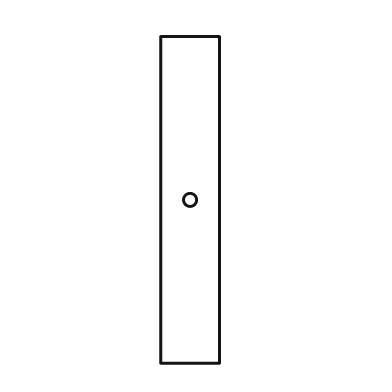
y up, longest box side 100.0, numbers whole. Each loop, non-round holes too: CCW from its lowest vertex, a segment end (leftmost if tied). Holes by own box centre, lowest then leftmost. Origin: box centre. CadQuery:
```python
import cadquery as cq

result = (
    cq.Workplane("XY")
    .moveTo(-9.0, -50.0)
    .lineTo(9.0, -50.0)
    .lineTo(9.0, 50.0)
    .lineTo(-9.0, 50.0)
    .close()
    .moveTo(0.0, 0.0)
    .circle(2.0)
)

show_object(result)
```